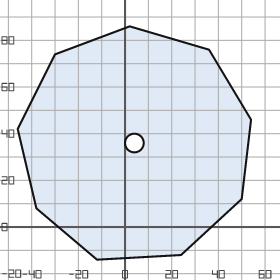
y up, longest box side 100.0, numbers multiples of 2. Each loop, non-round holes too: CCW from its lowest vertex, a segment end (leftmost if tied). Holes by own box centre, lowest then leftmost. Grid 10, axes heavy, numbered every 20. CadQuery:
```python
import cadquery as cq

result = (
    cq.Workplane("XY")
    .moveTo(-12.0, -14.0)
    .lineTo(24.0, -12.0)
    .lineTo(50.0, 12.0)
    .lineTo(54.0, 46.0)
    .lineTo(36.0, 76.0)
    .lineTo(2.0, 86.0)
    .lineTo(-30.0, 74.0)
    .lineTo(-46.0, 42.0)
    .lineTo(-38.0, 8.0)
    .close()
    .moveTo(4.0, 36.0)
    .circle(4.0)
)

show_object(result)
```